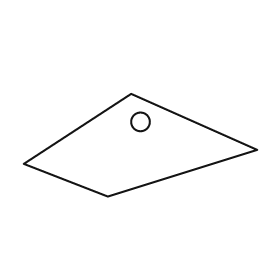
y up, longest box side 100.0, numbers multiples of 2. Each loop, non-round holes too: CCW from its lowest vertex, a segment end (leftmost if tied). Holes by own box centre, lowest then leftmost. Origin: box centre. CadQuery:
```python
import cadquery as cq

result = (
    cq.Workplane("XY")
    .moveTo(-14.0, -22.0)
    .lineTo(50.0, -2.0)
    .lineTo(-4.0, 22.0)
    .lineTo(-50.0, -8.0)
    .close()
    .moveTo(0.0, 10.0)
    .circle(4.0)
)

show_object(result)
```